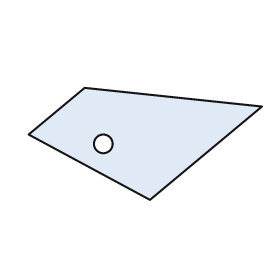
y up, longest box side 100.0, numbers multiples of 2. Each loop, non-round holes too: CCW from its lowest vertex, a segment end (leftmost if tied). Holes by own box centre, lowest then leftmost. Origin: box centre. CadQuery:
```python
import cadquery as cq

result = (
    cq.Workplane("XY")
    .moveTo(2.0, -24.0)
    .lineTo(50.0, 16.0)
    .lineTo(-26.0, 24.0)
    .lineTo(-50.0, 4.0)
    .close()
    .moveTo(-18.0, 0.0)
    .circle(4.0)
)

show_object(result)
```